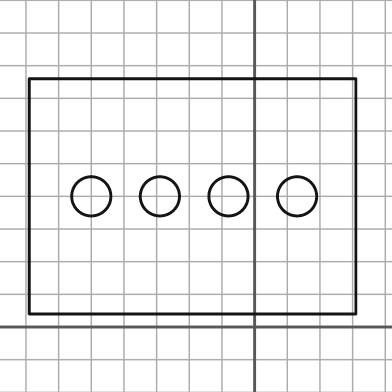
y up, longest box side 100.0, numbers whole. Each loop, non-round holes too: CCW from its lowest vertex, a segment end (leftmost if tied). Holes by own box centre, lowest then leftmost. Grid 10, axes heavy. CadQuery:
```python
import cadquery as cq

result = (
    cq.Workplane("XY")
    .moveTo(-69.0, 4.0)
    .lineTo(31.0, 4.0)
    .lineTo(31.0, 76.0)
    .lineTo(-69.0, 76.0)
    .close()
    .moveTo(-50.0, 40.0)
    .circle(6.0)
    .moveTo(-29.0, 40.0)
    .circle(6.0)
    .moveTo(-8.0, 40.0)
    .circle(6.0)
    .moveTo(13.0, 40.0)
    .circle(6.0)
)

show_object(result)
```